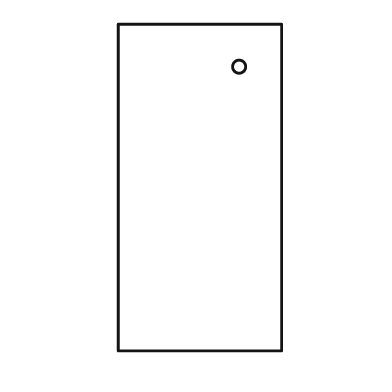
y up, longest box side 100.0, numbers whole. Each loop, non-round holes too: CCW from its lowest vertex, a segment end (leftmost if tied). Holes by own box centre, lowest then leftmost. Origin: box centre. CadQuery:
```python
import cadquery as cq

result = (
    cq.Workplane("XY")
    .moveTo(-25.0, -50.0)
    .lineTo(25.0, -50.0)
    .lineTo(25.0, 50.0)
    .lineTo(-25.0, 50.0)
    .close()
    .moveTo(12.0, 37.0)
    .circle(2.0)
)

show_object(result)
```